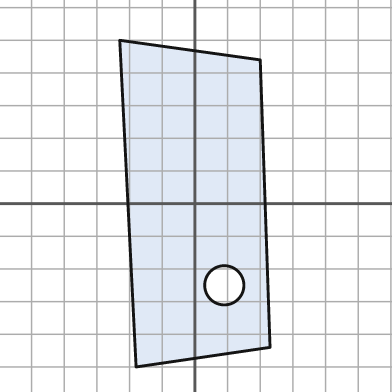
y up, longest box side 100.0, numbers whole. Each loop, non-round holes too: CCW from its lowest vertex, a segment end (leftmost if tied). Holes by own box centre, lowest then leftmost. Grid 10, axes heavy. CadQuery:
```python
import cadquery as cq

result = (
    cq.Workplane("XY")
    .moveTo(-18.0, -50.0)
    .lineTo(23.0, -44.0)
    .lineTo(20.0, 44.0)
    .lineTo(-23.0, 50.0)
    .close()
    .moveTo(9.0, -25.0)
    .circle(6.0)
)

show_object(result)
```